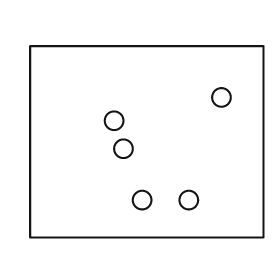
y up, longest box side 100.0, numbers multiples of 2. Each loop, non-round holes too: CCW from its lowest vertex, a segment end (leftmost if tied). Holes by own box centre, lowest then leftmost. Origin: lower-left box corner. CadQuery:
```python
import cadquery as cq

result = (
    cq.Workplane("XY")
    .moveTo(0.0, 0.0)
    .lineTo(100.0, 0.0)
    .lineTo(100.0, 82.0)
    .lineTo(0.0, 82.0)
    .close()
    .moveTo(48.0, 16.0)
    .circle(4.0)
    .moveTo(68.0, 16.0)
    .circle(4.0)
    .moveTo(40.0, 38.0)
    .circle(4.0)
    .moveTo(36.0, 50.0)
    .circle(4.0)
    .moveTo(82.0, 60.0)
    .circle(4.0)
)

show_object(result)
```